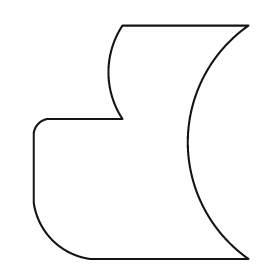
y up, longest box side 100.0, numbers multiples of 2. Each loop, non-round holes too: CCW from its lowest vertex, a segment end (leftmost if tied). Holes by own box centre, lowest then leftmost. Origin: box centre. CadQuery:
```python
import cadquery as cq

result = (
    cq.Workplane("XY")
    .moveTo(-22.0, -50.0)
    .lineTo(46.0, -50.0)
    .threePointArc((20.0, 0.0), (46.0, 50.0))
    .lineTo(-8.0, 50.0)
    .threePointArc((-14.0, 30.0), (-8.0, 10.0))
    .lineTo(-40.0, 10.0)
    .threePointArc((-44.0, 8.0), (-46.0, 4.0))
    .lineTo(-46.0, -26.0)
    .threePointArc((-38.0, -42.0), (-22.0, -50.0))
    .close()
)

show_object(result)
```